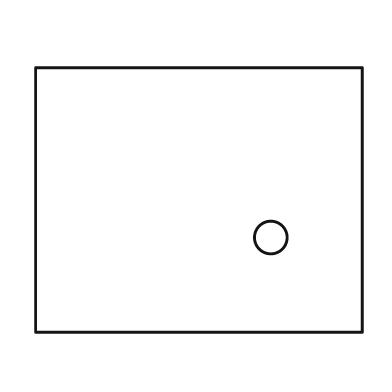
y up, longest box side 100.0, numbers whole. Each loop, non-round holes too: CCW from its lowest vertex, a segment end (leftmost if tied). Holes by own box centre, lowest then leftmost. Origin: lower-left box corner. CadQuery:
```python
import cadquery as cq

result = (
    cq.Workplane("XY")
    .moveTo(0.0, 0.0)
    .lineTo(100.0, 0.0)
    .lineTo(100.0, 81.0)
    .lineTo(0.0, 81.0)
    .close()
    .moveTo(72.0, 29.0)
    .circle(5.0)
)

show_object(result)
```